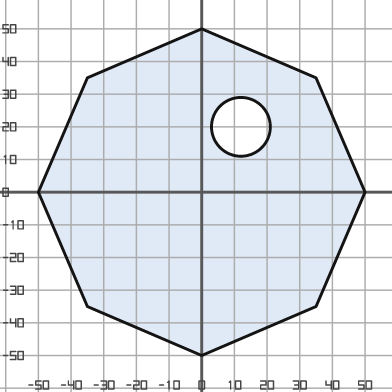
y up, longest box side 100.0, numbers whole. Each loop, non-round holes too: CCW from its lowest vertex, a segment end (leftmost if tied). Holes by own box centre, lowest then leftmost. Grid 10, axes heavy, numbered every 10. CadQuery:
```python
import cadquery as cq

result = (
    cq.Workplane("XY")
    .moveTo(0.0, -50.0)
    .lineTo(35.0, -35.0)
    .lineTo(50.0, 0.0)
    .lineTo(35.0, 35.0)
    .lineTo(0.0, 50.0)
    .lineTo(-35.0, 35.0)
    .lineTo(-50.0, 0.0)
    .lineTo(-35.0, -35.0)
    .close()
    .moveTo(12.0, 20.0)
    .circle(9.0)
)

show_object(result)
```